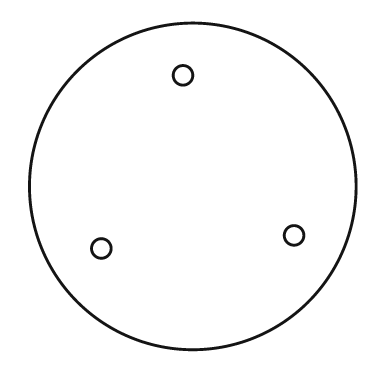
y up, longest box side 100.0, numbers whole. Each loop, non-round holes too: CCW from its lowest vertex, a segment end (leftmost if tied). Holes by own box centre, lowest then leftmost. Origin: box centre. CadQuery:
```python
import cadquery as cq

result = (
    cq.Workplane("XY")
    .moveTo(0.0, 0.0)
    .circle(50.0)
    .moveTo(-28.0, -19.0)
    .circle(3.0)
    .moveTo(31.0, -15.0)
    .circle(3.0)
    .moveTo(-3.0, 34.0)
    .circle(3.0)
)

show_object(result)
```